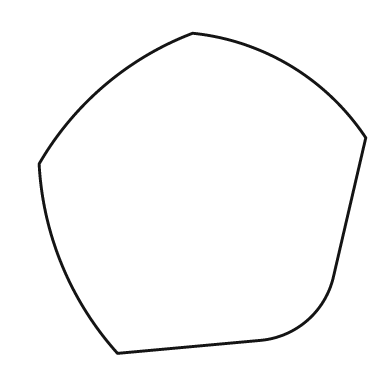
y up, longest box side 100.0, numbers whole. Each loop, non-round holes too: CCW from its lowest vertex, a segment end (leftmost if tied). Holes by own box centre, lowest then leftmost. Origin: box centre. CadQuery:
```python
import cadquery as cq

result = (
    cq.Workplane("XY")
    .moveTo(-26.0, -49.0)
    .lineTo(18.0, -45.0)
    .threePointArc((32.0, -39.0), (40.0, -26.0))
    .lineTo(50.0, 17.0)
    .threePointArc((27.0, 39.0), (-3.0, 49.0))
    .threePointArc((-30.0, 33.0), (-50.0, 9.0))
    .threePointArc((-43.0, -22.0), (-26.0, -49.0))
    .close()
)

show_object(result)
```